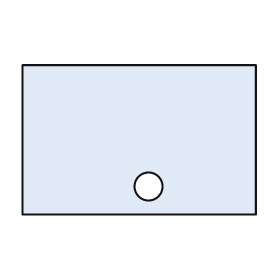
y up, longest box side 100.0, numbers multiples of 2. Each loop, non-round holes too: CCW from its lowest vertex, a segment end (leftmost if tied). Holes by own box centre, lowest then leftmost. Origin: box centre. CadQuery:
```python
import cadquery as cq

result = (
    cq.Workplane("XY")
    .moveTo(-50.0, -32.0)
    .lineTo(50.0, -32.0)
    .lineTo(50.0, 32.0)
    .lineTo(-50.0, 32.0)
    .close()
    .moveTo(4.0, -20.0)
    .circle(6.0)
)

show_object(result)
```